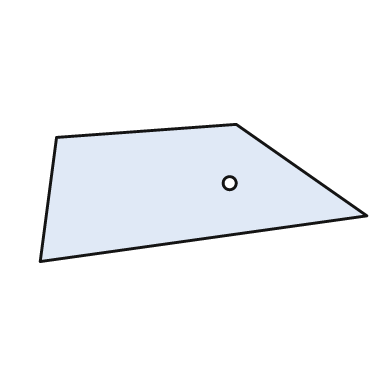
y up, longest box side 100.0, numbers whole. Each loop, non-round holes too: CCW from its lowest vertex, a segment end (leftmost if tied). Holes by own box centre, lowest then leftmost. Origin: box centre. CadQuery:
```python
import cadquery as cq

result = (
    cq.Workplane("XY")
    .moveTo(-50.0, -21.0)
    .lineTo(50.0, -7.0)
    .lineTo(10.0, 21.0)
    .lineTo(-45.0, 17.0)
    .close()
    .moveTo(8.0, 3.0)
    .circle(2.0)
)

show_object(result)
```